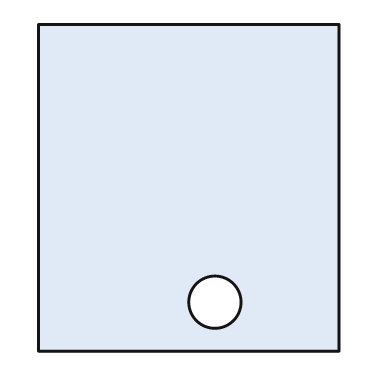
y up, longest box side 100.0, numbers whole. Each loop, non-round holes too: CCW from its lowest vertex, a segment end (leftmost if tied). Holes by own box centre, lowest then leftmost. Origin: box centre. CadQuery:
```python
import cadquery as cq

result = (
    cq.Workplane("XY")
    .moveTo(-46.0, -50.0)
    .lineTo(46.0, -50.0)
    .lineTo(46.0, 50.0)
    .lineTo(-46.0, 50.0)
    .close()
    .moveTo(8.0, -35.0)
    .circle(8.0)
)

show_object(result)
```